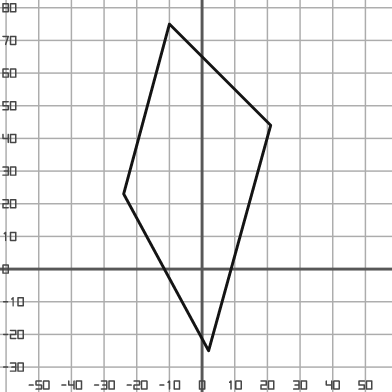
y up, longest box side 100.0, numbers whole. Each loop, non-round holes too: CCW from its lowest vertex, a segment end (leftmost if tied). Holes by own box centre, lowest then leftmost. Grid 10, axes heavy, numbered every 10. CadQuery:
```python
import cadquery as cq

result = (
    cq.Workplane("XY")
    .moveTo(2.0, -25.0)
    .lineTo(21.0, 44.0)
    .lineTo(-10.0, 75.0)
    .lineTo(-24.0, 23.0)
    .close()
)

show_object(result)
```